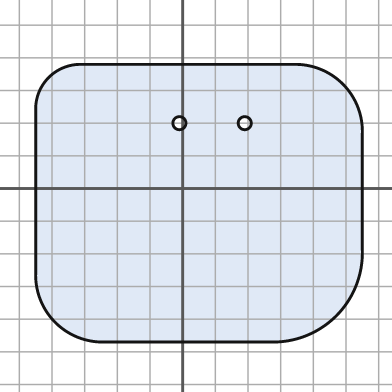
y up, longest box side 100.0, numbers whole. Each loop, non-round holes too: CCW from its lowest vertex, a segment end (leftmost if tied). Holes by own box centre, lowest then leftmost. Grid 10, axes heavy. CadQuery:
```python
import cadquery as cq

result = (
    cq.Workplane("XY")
    .moveTo(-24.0, -47.0)
    .lineTo(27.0, -47.0)
    .threePointArc((47.0, -39.0), (55.0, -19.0))
    .lineTo(55.0, 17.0)
    .threePointArc((49.0, 32.0), (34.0, 38.0))
    .lineTo(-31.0, 38.0)
    .threePointArc((-41.0, 34.0), (-45.0, 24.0))
    .lineTo(-45.0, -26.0)
    .threePointArc((-39.0, -41.0), (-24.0, -47.0))
    .close()
    .moveTo(-1.0, 20.0)
    .circle(2.0)
    .moveTo(19.0, 20.0)
    .circle(2.0)
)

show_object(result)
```